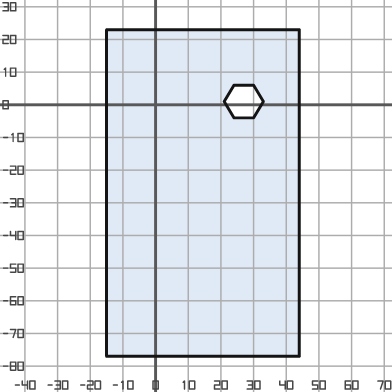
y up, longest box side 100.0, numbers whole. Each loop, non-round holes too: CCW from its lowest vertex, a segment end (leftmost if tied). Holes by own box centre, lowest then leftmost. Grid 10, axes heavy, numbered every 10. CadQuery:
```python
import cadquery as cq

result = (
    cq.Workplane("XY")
    .moveTo(-15.0, -77.0)
    .lineTo(44.0, -77.0)
    .lineTo(44.0, 23.0)
    .lineTo(-15.0, 23.0)
    .close()
    .moveTo(24.0, -4.0)
    .lineTo(30.0, -4.0)
    .lineTo(33.0, 1.0)
    .lineTo(30.0, 6.0)
    .lineTo(24.0, 6.0)
    .lineTo(21.0, 1.0)
    .close()
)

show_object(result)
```